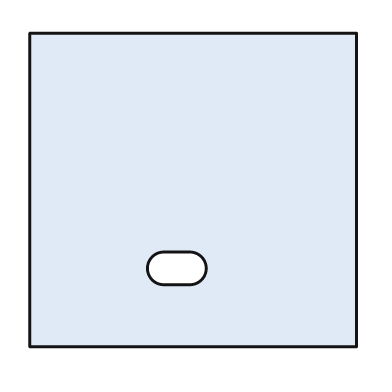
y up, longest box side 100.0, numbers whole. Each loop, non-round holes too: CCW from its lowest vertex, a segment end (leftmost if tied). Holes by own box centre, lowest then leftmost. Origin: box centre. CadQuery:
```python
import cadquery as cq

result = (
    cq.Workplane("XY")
    .moveTo(-50.0, -48.0)
    .lineTo(50.0, -48.0)
    .lineTo(50.0, 48.0)
    .lineTo(-50.0, 48.0)
    .close()
    .moveTo(-9.0, -29.0)
    .lineTo(-1.0, -29.0)
    .threePointArc((4.0, -24.0), (-1.0, -19.0))
    .lineTo(-9.0, -19.0)
    .threePointArc((-14.0, -24.0), (-9.0, -29.0))
    .close()
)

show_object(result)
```